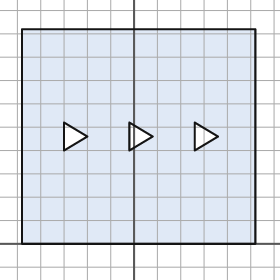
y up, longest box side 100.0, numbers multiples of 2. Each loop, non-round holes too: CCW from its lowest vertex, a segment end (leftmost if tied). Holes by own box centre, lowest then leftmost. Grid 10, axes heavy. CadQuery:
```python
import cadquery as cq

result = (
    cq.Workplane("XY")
    .moveTo(-48.0, 0.0)
    .lineTo(52.0, 0.0)
    .lineTo(52.0, 92.0)
    .lineTo(-48.0, 92.0)
    .close()
    .moveTo(-30.0, 40.0)
    .lineTo(-20.0, 46.0)
    .lineTo(-30.0, 52.0)
    .close()
    .moveTo(-2.0, 40.0)
    .lineTo(8.0, 46.0)
    .lineTo(-2.0, 52.0)
    .close()
    .moveTo(26.0, 40.0)
    .lineTo(36.0, 46.0)
    .lineTo(26.0, 52.0)
    .close()
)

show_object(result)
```